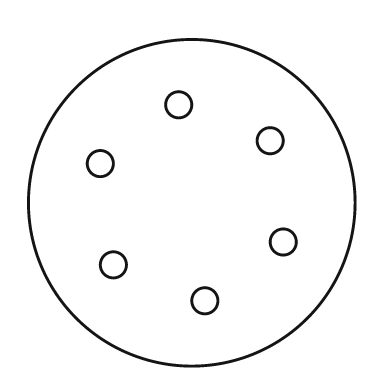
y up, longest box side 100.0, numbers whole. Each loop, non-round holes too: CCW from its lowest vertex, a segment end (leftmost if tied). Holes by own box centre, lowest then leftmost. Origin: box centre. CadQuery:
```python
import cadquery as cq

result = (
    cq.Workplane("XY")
    .moveTo(0.0, 0.0)
    .circle(50.0)
    .moveTo(4.0, -30.0)
    .circle(4.0)
    .moveTo(-24.0, -19.0)
    .circle(4.0)
    .moveTo(28.0, -12.0)
    .circle(4.0)
    .moveTo(-28.0, 12.0)
    .circle(4.0)
    .moveTo(24.0, 19.0)
    .circle(4.0)
    .moveTo(-4.0, 30.0)
    .circle(4.0)
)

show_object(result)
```